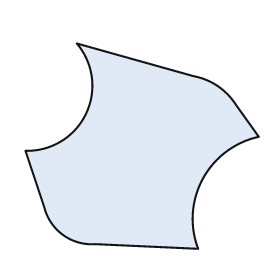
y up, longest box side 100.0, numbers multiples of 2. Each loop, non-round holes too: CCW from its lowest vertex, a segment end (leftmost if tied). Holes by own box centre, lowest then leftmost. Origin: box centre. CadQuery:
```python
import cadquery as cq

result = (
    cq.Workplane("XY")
    .moveTo(24.0, -44.0)
    .threePointArc((26.0, -14.0), (50.0, 4.0))
    .lineTo(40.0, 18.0)
    .threePointArc((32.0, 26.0), (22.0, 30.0))
    .lineTo(-28.0, 44.0)
    .threePointArc((-24.0, 14.0), (-50.0, -2.0))
    .lineTo(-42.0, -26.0)
    .threePointArc((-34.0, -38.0), (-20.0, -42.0))
    .close()
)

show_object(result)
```